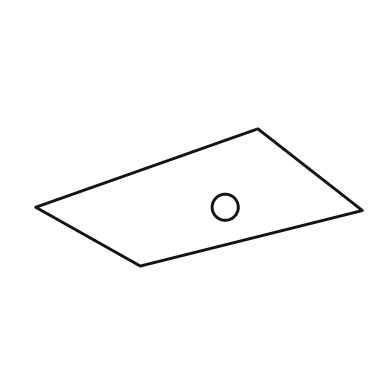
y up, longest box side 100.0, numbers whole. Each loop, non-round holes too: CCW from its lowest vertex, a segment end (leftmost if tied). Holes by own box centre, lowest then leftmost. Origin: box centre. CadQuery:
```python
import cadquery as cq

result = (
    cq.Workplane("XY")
    .moveTo(-18.0, -21.0)
    .lineTo(50.0, -4.0)
    .lineTo(18.0, 21.0)
    .lineTo(-50.0, -3.0)
    .close()
    .moveTo(8.0, -3.0)
    .circle(4.0)
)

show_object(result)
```